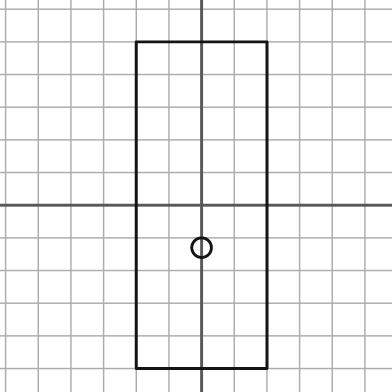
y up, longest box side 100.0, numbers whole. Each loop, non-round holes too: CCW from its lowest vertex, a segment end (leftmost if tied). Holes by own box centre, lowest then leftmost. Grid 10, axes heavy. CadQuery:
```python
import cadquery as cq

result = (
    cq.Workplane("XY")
    .moveTo(-20.0, -50.0)
    .lineTo(20.0, -50.0)
    .lineTo(20.0, 50.0)
    .lineTo(-20.0, 50.0)
    .close()
    .moveTo(0.0, -13.0)
    .circle(3.0)
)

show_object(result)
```